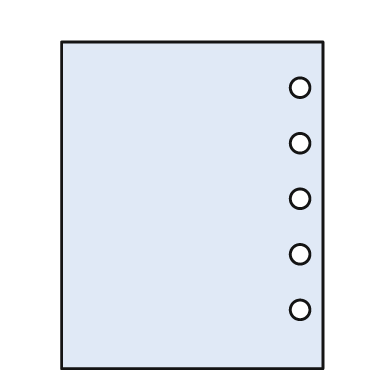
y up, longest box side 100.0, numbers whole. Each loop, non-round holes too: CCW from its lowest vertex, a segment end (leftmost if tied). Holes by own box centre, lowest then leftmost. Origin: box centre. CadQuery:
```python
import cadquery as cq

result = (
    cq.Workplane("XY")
    .moveTo(-40.0, -50.0)
    .lineTo(40.0, -50.0)
    .lineTo(40.0, 50.0)
    .lineTo(-40.0, 50.0)
    .close()
    .moveTo(33.0, -32.0)
    .circle(3.0)
    .moveTo(33.0, -15.0)
    .circle(3.0)
    .moveTo(33.0, 2.0)
    .circle(3.0)
    .moveTo(33.0, 19.0)
    .circle(3.0)
    .moveTo(33.0, 36.0)
    .circle(3.0)
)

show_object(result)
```